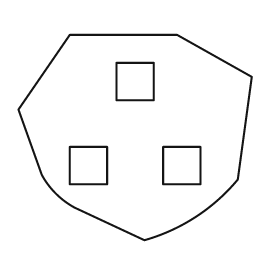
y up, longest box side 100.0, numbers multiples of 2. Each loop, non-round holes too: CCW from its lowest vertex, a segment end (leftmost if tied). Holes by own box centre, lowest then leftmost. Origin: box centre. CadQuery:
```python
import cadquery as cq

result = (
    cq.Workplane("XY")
    .moveTo(4.0, -44.0)
    .threePointArc((26.0, -34.0), (44.0, -18.0))
    .lineTo(50.0, 26.0)
    .lineTo(18.0, 44.0)
    .lineTo(-28.0, 44.0)
    .lineTo(-50.0, 12.0)
    .lineTo(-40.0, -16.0)
    .threePointArc((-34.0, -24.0), (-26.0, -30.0))
    .close()
    .moveTo(-28.0, -20.0)
    .lineTo(-12.0, -20.0)
    .lineTo(-12.0, -4.0)
    .lineTo(-28.0, -4.0)
    .close()
    .moveTo(12.0, -20.0)
    .lineTo(28.0, -20.0)
    .lineTo(28.0, -4.0)
    .lineTo(12.0, -4.0)
    .close()
    .moveTo(-8.0, 16.0)
    .lineTo(8.0, 16.0)
    .lineTo(8.0, 32.0)
    .lineTo(-8.0, 32.0)
    .close()
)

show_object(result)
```